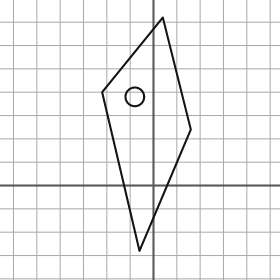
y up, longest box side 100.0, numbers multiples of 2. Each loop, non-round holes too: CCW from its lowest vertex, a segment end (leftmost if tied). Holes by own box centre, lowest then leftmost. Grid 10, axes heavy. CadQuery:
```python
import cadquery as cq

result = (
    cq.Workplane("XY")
    .moveTo(-6.0, -28.0)
    .lineTo(16.0, 24.0)
    .lineTo(4.0, 72.0)
    .lineTo(-22.0, 40.0)
    .close()
    .moveTo(-8.0, 38.0)
    .circle(4.0)
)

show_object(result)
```